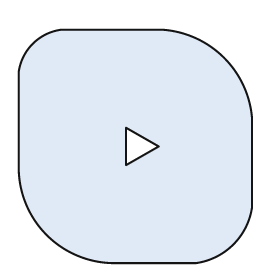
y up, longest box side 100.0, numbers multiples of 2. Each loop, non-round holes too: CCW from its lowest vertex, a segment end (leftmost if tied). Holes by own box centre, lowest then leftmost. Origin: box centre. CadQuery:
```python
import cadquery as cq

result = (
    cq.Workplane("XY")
    .moveTo(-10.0, -50.0)
    .lineTo(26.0, -50.0)
    .threePointArc((42.0, -42.0), (50.0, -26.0))
    .lineTo(50.0, 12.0)
    .threePointArc((38.0, 38.0), (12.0, 50.0))
    .lineTo(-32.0, 50.0)
    .threePointArc((-44.0, 44.0), (-50.0, 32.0))
    .lineTo(-50.0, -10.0)
    .threePointArc((-38.0, -38.0), (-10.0, -50.0))
    .close()
    .moveTo(-4.0, -8.0)
    .lineTo(10.0, 0.0)
    .lineTo(-4.0, 8.0)
    .close()
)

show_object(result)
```